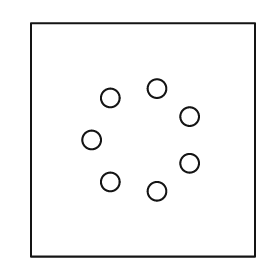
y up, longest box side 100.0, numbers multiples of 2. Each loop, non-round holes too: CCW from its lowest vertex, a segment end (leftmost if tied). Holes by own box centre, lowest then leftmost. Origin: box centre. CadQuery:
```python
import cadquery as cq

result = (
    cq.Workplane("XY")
    .moveTo(-48.0, -50.0)
    .lineTo(48.0, -50.0)
    .lineTo(48.0, 50.0)
    .lineTo(-48.0, 50.0)
    .close()
    .moveTo(6.0, -22.0)
    .circle(4.0)
    .moveTo(-14.0, -18.0)
    .circle(4.0)
    .moveTo(20.0, -10.0)
    .circle(4.0)
    .moveTo(-22.0, 0.0)
    .circle(4.0)
    .moveTo(20.0, 10.0)
    .circle(4.0)
    .moveTo(-14.0, 18.0)
    .circle(4.0)
    .moveTo(6.0, 22.0)
    .circle(4.0)
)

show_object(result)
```